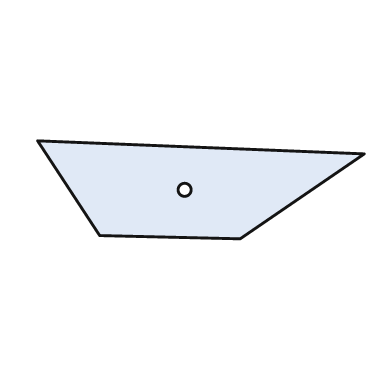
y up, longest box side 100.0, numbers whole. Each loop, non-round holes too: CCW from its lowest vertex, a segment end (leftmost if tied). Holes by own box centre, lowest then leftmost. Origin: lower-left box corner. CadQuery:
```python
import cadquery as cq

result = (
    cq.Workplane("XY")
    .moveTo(62.0, 0.0)
    .lineTo(100.0, 26.0)
    .lineTo(0.0, 30.0)
    .lineTo(19.0, 1.0)
    .close()
    .moveTo(45.0, 15.0)
    .circle(2.0)
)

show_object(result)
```